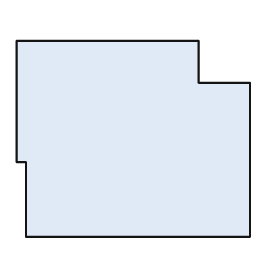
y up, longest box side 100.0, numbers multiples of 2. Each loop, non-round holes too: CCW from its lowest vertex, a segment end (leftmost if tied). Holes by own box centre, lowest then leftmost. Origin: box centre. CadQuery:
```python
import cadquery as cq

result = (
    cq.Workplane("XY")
    .moveTo(-46.0, -42.0)
    .lineTo(50.0, -42.0)
    .lineTo(50.0, 24.0)
    .lineTo(28.0, 24.0)
    .lineTo(28.0, 42.0)
    .lineTo(-50.0, 42.0)
    .lineTo(-50.0, -10.0)
    .lineTo(-46.0, -10.0)
    .close()
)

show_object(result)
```